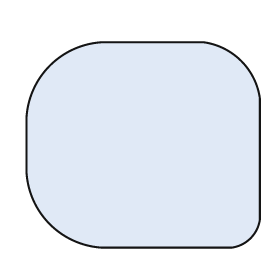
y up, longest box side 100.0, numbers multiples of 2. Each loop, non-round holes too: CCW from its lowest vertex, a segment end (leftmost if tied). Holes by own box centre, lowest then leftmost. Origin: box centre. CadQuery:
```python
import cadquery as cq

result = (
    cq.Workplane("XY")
    .moveTo(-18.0, -44.0)
    .lineTo(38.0, -44.0)
    .threePointArc((46.0, -40.0), (50.0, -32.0))
    .lineTo(50.0, 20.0)
    .threePointArc((42.0, 36.0), (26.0, 44.0))
    .lineTo(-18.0, 44.0)
    .threePointArc((-40.0, 34.0), (-50.0, 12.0))
    .lineTo(-50.0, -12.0)
    .threePointArc((-40.0, -34.0), (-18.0, -44.0))
    .close()
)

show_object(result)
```